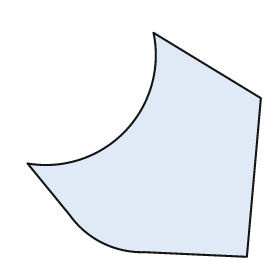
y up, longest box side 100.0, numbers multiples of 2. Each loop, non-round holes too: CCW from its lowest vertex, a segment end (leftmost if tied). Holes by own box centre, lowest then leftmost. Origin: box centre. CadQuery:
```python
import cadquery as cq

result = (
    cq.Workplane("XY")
    .moveTo(44.0, -48.0)
    .lineTo(50.0, 20.0)
    .lineTo(4.0, 48.0)
    .threePointArc((-8.0, 6.0), (-50.0, -8.0))
    .lineTo(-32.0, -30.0)
    .threePointArc((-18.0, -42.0), (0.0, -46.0))
    .close()
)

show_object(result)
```